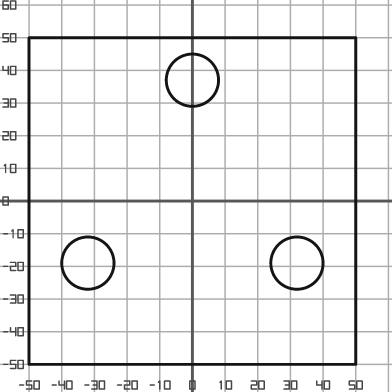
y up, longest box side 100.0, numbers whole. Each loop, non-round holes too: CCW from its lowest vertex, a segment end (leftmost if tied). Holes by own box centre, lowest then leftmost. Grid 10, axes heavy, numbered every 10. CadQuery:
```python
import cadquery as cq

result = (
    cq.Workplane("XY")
    .moveTo(-50.0, -50.0)
    .lineTo(50.0, -50.0)
    .lineTo(50.0, 50.0)
    .lineTo(-50.0, 50.0)
    .close()
    .moveTo(-32.0, -19.0)
    .circle(8.0)
    .moveTo(32.0, -19.0)
    .circle(8.0)
    .moveTo(0.0, 37.0)
    .circle(8.0)
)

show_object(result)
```